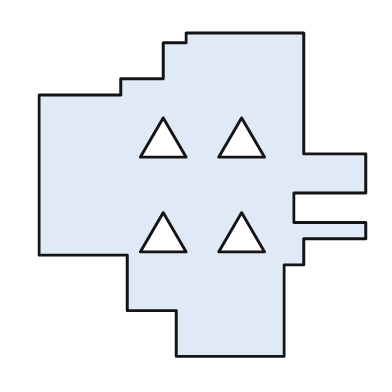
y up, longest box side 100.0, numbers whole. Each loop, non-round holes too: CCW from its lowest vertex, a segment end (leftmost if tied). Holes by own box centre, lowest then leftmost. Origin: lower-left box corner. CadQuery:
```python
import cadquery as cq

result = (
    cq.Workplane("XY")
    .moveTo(42.0, 0.0)
    .lineTo(75.0, 0.0)
    .lineTo(75.0, 28.0)
    .lineTo(81.0, 28.0)
    .lineTo(81.0, 36.0)
    .lineTo(100.0, 36.0)
    .lineTo(100.0, 41.0)
    .lineTo(78.0, 41.0)
    .lineTo(78.0, 50.0)
    .lineTo(100.0, 50.0)
    .lineTo(100.0, 62.0)
    .lineTo(81.0, 62.0)
    .lineTo(81.0, 99.0)
    .lineTo(45.0, 99.0)
    .lineTo(45.0, 96.0)
    .lineTo(38.0, 96.0)
    .lineTo(38.0, 85.0)
    .lineTo(25.0, 85.0)
    .lineTo(25.0, 80.0)
    .lineTo(0.0, 80.0)
    .lineTo(0.0, 31.0)
    .lineTo(27.0, 31.0)
    .lineTo(27.0, 14.0)
    .lineTo(42.0, 14.0)
    .close()
    .moveTo(31.0, 32.0)
    .lineTo(45.0, 32.0)
    .lineTo(38.0, 44.0)
    .close()
    .moveTo(55.0, 32.0)
    .lineTo(69.0, 32.0)
    .lineTo(62.0, 44.0)
    .close()
    .moveTo(31.0, 61.0)
    .lineTo(45.0, 61.0)
    .lineTo(38.0, 73.0)
    .close()
    .moveTo(55.0, 61.0)
    .lineTo(69.0, 61.0)
    .lineTo(62.0, 73.0)
    .close()
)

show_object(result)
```